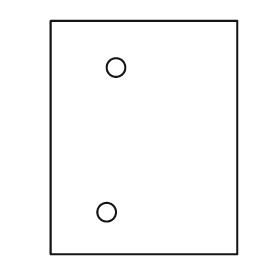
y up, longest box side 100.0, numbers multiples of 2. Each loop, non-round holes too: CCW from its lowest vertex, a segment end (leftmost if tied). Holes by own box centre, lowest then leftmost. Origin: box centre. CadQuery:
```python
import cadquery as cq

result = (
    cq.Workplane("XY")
    .moveTo(-40.0, -50.0)
    .lineTo(40.0, -50.0)
    .lineTo(40.0, 50.0)
    .lineTo(-40.0, 50.0)
    .close()
    .moveTo(-16.0, -32.0)
    .circle(4.0)
    .moveTo(-12.0, 30.0)
    .circle(4.0)
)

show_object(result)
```